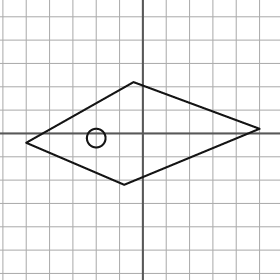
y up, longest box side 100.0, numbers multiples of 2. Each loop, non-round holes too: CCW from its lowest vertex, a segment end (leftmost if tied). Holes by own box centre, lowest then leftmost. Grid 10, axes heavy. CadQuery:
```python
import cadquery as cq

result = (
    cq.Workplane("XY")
    .moveTo(-8.0, -22.0)
    .lineTo(50.0, 2.0)
    .lineTo(-4.0, 22.0)
    .lineTo(-50.0, -4.0)
    .close()
    .moveTo(-20.0, -2.0)
    .circle(4.0)
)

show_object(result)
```